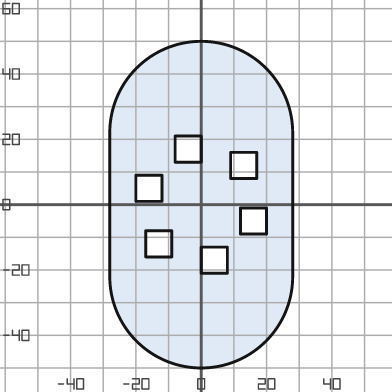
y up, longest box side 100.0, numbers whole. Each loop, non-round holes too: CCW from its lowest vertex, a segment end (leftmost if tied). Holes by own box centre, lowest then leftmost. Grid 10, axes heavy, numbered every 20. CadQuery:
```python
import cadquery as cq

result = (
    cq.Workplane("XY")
    .moveTo(-28.0, -22.0)
    .threePointArc((0.0, -50.0), (28.0, -22.0))
    .lineTo(28.0, 22.0)
    .threePointArc((0.0, 50.0), (-28.0, 22.0))
    .close()
    .moveTo(0.0, -21.0)
    .lineTo(8.0, -21.0)
    .lineTo(8.0, -13.0)
    .lineTo(0.0, -13.0)
    .close()
    .moveTo(-17.0, -16.0)
    .lineTo(-9.0, -16.0)
    .lineTo(-9.0, -8.0)
    .lineTo(-17.0, -8.0)
    .close()
    .moveTo(12.0, -9.0)
    .lineTo(20.0, -9.0)
    .lineTo(20.0, -1.0)
    .lineTo(12.0, -1.0)
    .close()
    .moveTo(-20.0, 1.0)
    .lineTo(-12.0, 1.0)
    .lineTo(-12.0, 9.0)
    .lineTo(-20.0, 9.0)
    .close()
    .moveTo(9.0, 8.0)
    .lineTo(17.0, 8.0)
    .lineTo(17.0, 16.0)
    .lineTo(9.0, 16.0)
    .close()
    .moveTo(-8.0, 13.0)
    .lineTo(0.0, 13.0)
    .lineTo(0.0, 21.0)
    .lineTo(-8.0, 21.0)
    .close()
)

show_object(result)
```